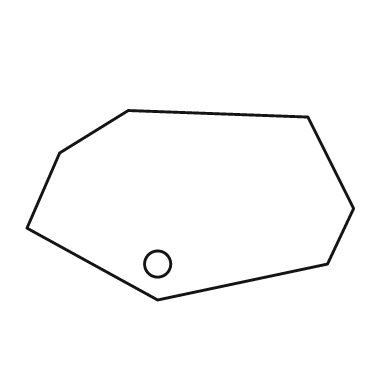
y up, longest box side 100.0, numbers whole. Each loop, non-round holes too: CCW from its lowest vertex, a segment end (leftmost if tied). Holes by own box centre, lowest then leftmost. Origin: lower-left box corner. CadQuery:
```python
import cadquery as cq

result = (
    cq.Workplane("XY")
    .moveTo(40.0, 0.0)
    .lineTo(92.0, 11.0)
    .lineTo(100.0, 28.0)
    .lineTo(86.0, 56.0)
    .lineTo(31.0, 58.0)
    .lineTo(10.0, 45.0)
    .lineTo(0.0, 22.0)
    .close()
    .moveTo(40.0, 11.0)
    .circle(4.0)
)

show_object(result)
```